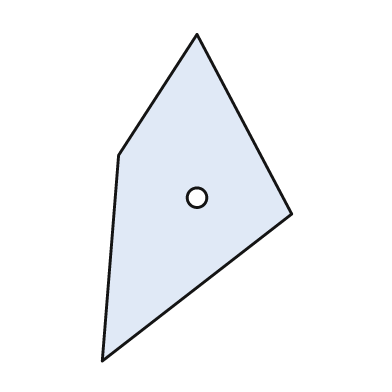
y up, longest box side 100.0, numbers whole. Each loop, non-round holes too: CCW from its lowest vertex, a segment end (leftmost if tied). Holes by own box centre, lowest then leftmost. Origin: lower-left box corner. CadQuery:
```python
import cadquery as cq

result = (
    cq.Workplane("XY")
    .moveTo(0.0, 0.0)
    .lineTo(58.0, 45.0)
    .lineTo(29.0, 100.0)
    .lineTo(5.0, 63.0)
    .close()
    .moveTo(29.0, 50.0)
    .circle(3.0)
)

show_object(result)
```